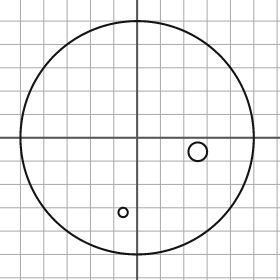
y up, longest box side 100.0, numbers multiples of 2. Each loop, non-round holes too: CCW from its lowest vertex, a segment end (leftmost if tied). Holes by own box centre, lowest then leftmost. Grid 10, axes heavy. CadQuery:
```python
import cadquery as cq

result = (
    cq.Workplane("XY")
    .moveTo(0.0, 0.0)
    .circle(50.0)
    .moveTo(-6.0, -32.0)
    .circle(2.0)
    .moveTo(26.0, -6.0)
    .circle(4.0)
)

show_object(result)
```